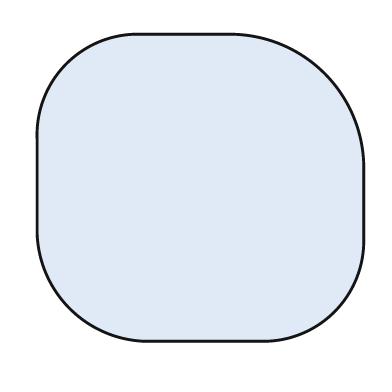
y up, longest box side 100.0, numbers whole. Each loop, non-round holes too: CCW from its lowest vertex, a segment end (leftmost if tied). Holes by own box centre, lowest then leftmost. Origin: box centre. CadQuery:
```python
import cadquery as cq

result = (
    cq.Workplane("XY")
    .moveTo(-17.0, -47.0)
    .lineTo(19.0, -47.0)
    .threePointArc((41.0, -38.0), (50.0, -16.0))
    .lineTo(50.0, 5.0)
    .threePointArc((38.0, 35.0), (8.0, 47.0))
    .lineTo(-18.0, 47.0)
    .threePointArc((-41.0, 38.0), (-50.0, 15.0))
    .lineTo(-50.0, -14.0)
    .threePointArc((-40.0, -37.0), (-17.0, -47.0))
    .close()
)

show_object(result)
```